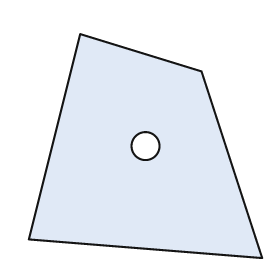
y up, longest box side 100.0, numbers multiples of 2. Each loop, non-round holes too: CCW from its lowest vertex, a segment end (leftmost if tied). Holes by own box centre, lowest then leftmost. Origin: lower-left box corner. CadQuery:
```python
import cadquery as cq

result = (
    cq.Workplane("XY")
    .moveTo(100.0, 0.0)
    .lineTo(74.0, 80.0)
    .lineTo(22.0, 96.0)
    .lineTo(0.0, 8.0)
    .close()
    .moveTo(50.0, 48.0)
    .circle(6.0)
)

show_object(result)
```